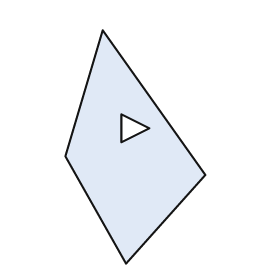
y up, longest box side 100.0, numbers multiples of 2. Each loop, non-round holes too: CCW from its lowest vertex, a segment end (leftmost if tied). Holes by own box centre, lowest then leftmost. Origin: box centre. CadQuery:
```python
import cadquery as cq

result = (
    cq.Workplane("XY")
    .moveTo(-4.0, -50.0)
    .lineTo(30.0, -12.0)
    .lineTo(-14.0, 50.0)
    .lineTo(-30.0, -4.0)
    .close()
    .moveTo(-6.0, 2.0)
    .lineTo(6.0, 8.0)
    .lineTo(-6.0, 14.0)
    .close()
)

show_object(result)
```